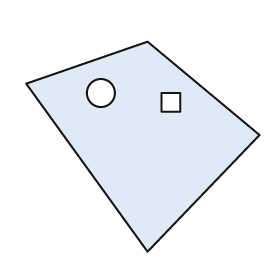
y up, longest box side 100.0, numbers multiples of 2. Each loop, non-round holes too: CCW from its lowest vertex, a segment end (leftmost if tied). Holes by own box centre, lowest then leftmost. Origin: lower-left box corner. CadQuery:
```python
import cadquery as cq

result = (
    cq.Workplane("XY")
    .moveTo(52.0, 0.0)
    .lineTo(100.0, 50.0)
    .lineTo(52.0, 90.0)
    .lineTo(0.0, 72.0)
    .close()
    .moveTo(58.0, 60.0)
    .lineTo(66.0, 60.0)
    .lineTo(66.0, 68.0)
    .lineTo(58.0, 68.0)
    .close()
    .moveTo(32.0, 68.0)
    .circle(6.0)
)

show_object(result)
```